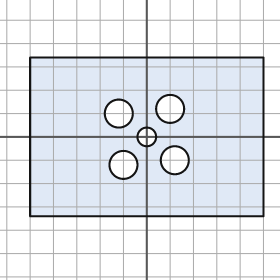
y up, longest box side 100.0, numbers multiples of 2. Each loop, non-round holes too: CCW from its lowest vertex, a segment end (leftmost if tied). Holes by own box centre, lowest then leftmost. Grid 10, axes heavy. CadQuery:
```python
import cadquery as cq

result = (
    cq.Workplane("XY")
    .moveTo(-50.0, -34.0)
    .lineTo(50.0, -34.0)
    .lineTo(50.0, 34.0)
    .lineTo(-50.0, 34.0)
    .close()
    .moveTo(-10.0, -12.0)
    .circle(6.0)
    .moveTo(12.0, -10.0)
    .circle(6.0)
    .moveTo(0.0, 0.0)
    .circle(4.0)
    .moveTo(-12.0, 10.0)
    .circle(6.0)
    .moveTo(10.0, 12.0)
    .circle(6.0)
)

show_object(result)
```